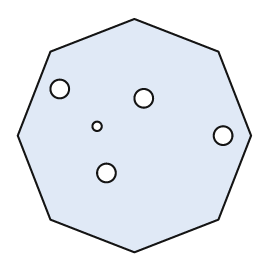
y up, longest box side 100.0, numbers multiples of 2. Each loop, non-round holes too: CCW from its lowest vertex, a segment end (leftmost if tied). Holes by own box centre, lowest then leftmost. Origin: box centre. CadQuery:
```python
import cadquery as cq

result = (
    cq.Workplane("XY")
    .moveTo(0.0, -50.0)
    .lineTo(36.0, -36.0)
    .lineTo(50.0, 0.0)
    .lineTo(36.0, 36.0)
    .lineTo(0.0, 50.0)
    .lineTo(-36.0, 36.0)
    .lineTo(-50.0, 0.0)
    .lineTo(-36.0, -36.0)
    .close()
    .moveTo(-12.0, -16.0)
    .circle(4.0)
    .moveTo(38.0, 0.0)
    .circle(4.0)
    .moveTo(-16.0, 4.0)
    .circle(2.0)
    .moveTo(4.0, 16.0)
    .circle(4.0)
    .moveTo(-32.0, 20.0)
    .circle(4.0)
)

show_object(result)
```